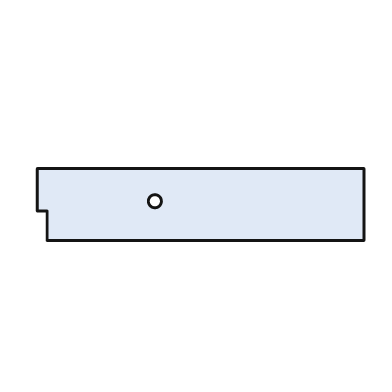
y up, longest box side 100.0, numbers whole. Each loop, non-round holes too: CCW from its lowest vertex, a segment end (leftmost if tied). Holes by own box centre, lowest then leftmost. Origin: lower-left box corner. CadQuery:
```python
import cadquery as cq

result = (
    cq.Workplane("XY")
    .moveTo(3.0, 0.0)
    .lineTo(100.0, 0.0)
    .lineTo(100.0, 22.0)
    .lineTo(0.0, 22.0)
    .lineTo(0.0, 9.0)
    .lineTo(3.0, 9.0)
    .close()
    .moveTo(36.0, 12.0)
    .circle(2.0)
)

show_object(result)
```